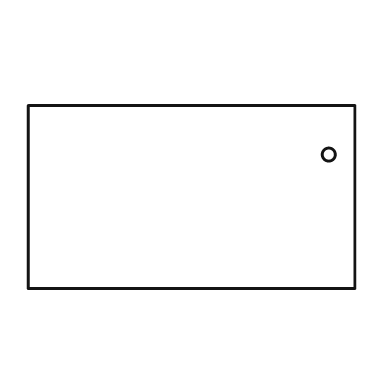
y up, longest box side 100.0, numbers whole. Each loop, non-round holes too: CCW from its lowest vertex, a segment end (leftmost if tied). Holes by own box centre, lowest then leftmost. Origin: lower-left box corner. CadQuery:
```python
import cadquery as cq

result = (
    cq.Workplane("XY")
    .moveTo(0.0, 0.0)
    .lineTo(100.0, 0.0)
    .lineTo(100.0, 56.0)
    .lineTo(0.0, 56.0)
    .close()
    .moveTo(92.0, 41.0)
    .circle(2.0)
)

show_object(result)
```